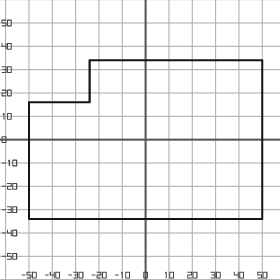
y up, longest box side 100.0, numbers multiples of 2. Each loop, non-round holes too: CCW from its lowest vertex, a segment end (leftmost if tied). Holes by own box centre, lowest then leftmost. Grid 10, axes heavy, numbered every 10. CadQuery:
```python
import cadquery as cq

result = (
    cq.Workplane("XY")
    .moveTo(-50.0, -34.0)
    .lineTo(50.0, -34.0)
    .lineTo(50.0, 34.0)
    .lineTo(-24.0, 34.0)
    .lineTo(-24.0, 16.0)
    .lineTo(-50.0, 16.0)
    .close()
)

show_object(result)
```